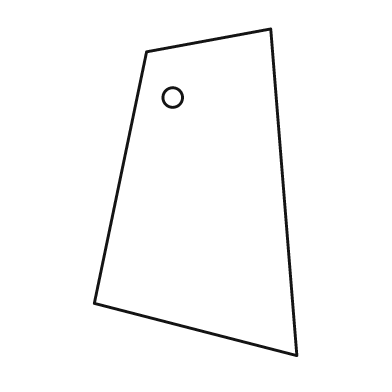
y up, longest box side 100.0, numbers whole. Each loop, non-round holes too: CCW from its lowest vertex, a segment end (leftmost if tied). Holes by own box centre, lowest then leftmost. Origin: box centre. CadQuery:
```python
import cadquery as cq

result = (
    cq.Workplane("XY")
    .moveTo(31.0, -50.0)
    .lineTo(23.0, 50.0)
    .lineTo(-15.0, 43.0)
    .lineTo(-31.0, -34.0)
    .close()
    .moveTo(-7.0, 29.0)
    .circle(3.0)
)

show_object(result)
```